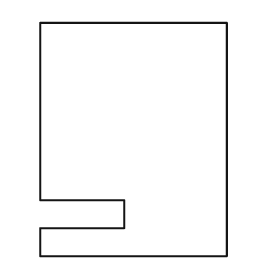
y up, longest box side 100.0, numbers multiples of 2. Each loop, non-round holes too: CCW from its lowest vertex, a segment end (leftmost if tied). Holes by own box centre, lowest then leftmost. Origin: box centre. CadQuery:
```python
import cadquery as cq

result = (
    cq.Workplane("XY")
    .moveTo(-40.0, -50.0)
    .lineTo(40.0, -50.0)
    .lineTo(40.0, 50.0)
    .lineTo(-40.0, 50.0)
    .lineTo(-40.0, -26.0)
    .lineTo(-4.0, -26.0)
    .lineTo(-4.0, -38.0)
    .lineTo(-40.0, -38.0)
    .close()
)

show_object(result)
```